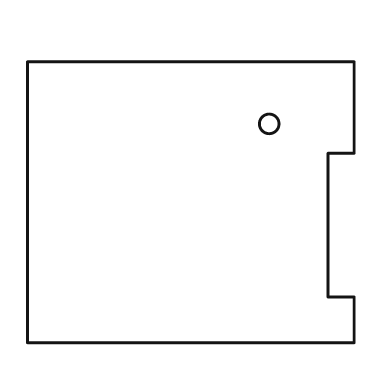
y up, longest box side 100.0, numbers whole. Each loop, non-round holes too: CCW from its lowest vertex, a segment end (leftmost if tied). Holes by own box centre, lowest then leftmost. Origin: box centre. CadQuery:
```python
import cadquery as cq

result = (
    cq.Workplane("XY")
    .moveTo(-50.0, -43.0)
    .lineTo(50.0, -43.0)
    .lineTo(50.0, -29.0)
    .lineTo(42.0, -29.0)
    .lineTo(42.0, 15.0)
    .lineTo(50.0, 15.0)
    .lineTo(50.0, 43.0)
    .lineTo(-50.0, 43.0)
    .close()
    .moveTo(24.0, 24.0)
    .circle(3.0)
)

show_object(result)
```